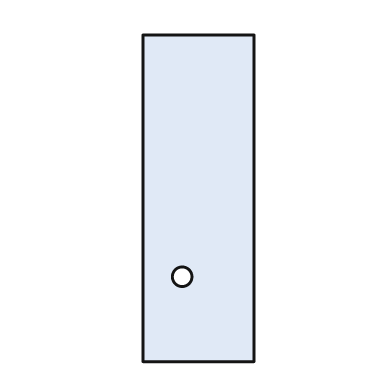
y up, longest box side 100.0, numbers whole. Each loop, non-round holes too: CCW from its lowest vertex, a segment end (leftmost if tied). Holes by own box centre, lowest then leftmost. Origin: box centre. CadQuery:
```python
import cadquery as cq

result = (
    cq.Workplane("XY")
    .moveTo(-17.0, -50.0)
    .lineTo(17.0, -50.0)
    .lineTo(17.0, 50.0)
    .lineTo(-17.0, 50.0)
    .close()
    .moveTo(-5.0, -24.0)
    .circle(3.0)
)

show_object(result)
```